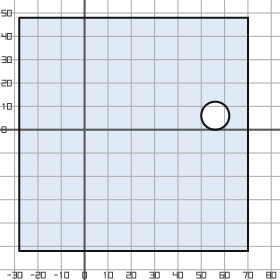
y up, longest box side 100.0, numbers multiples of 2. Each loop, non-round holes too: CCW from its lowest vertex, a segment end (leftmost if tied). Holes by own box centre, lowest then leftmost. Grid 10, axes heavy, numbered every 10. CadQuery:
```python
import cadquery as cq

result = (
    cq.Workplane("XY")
    .moveTo(-28.0, -52.0)
    .lineTo(70.0, -52.0)
    .lineTo(70.0, 48.0)
    .lineTo(-28.0, 48.0)
    .close()
    .moveTo(56.0, 6.0)
    .circle(6.0)
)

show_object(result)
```